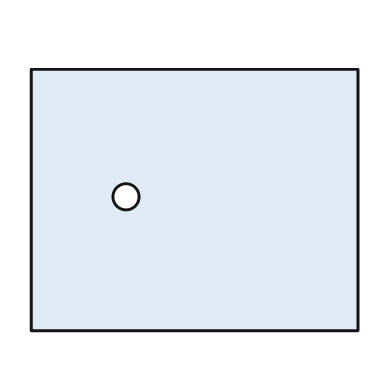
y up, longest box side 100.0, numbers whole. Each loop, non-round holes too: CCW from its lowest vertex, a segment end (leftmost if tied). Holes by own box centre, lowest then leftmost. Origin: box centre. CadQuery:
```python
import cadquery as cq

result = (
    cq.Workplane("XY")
    .moveTo(-50.0, -40.0)
    .lineTo(50.0, -40.0)
    .lineTo(50.0, 40.0)
    .lineTo(-50.0, 40.0)
    .close()
    .moveTo(-21.0, 1.0)
    .circle(4.0)
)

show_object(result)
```